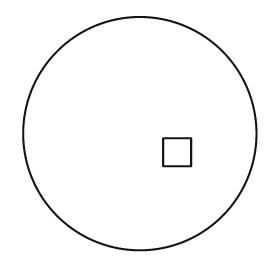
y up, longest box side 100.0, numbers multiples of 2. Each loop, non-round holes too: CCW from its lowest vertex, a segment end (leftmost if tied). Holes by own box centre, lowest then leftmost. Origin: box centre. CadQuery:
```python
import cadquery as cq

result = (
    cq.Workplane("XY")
    .moveTo(0.0, 0.0)
    .circle(50.0)
    .moveTo(10.0, -14.0)
    .lineTo(22.0, -14.0)
    .lineTo(22.0, -2.0)
    .lineTo(10.0, -2.0)
    .close()
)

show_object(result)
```